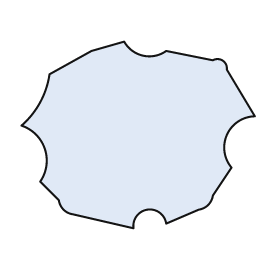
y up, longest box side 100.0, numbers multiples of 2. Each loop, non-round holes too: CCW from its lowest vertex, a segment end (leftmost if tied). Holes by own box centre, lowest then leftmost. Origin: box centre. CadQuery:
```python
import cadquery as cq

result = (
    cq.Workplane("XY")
    .moveTo(-2.0, -40.0)
    .threePointArc((4.0, -32.0), (12.0, -38.0))
    .lineTo(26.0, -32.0)
    .threePointArc((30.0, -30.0), (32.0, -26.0))
    .lineTo(40.0, -14.0)
    .threePointArc((38.0, 0.0), (50.0, 8.0))
    .lineTo(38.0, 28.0)
    .threePointArc((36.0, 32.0), (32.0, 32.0))
    .lineTo(12.0, 36.0)
    .threePointArc((2.0, 34.0), (-6.0, 40.0))
    .lineTo(-20.0, 36.0)
    .lineTo(-38.0, 26.0)
    .threePointArc((-42.0, 14.0), (-50.0, 4.0))
    .threePointArc((-40.0, -6.0), (-42.0, -20.0))
    .lineTo(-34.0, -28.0)
    .threePointArc((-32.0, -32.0), (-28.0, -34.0))
    .close()
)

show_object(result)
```